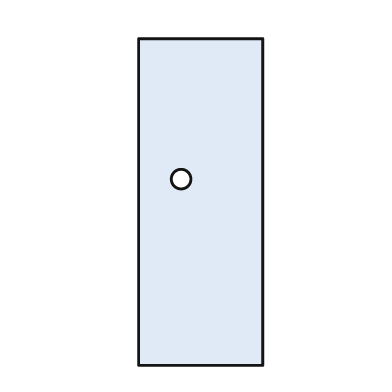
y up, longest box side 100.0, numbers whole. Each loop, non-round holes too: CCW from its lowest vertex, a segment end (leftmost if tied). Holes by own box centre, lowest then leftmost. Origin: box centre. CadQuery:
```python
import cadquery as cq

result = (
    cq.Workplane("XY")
    .moveTo(-19.0, -50.0)
    .lineTo(19.0, -50.0)
    .lineTo(19.0, 50.0)
    .lineTo(-19.0, 50.0)
    .close()
    .moveTo(-6.0, 7.0)
    .circle(3.0)
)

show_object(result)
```